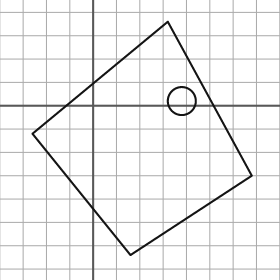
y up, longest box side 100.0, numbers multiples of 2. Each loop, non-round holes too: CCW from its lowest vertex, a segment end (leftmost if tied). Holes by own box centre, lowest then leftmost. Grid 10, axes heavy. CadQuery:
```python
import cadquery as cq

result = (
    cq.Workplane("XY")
    .moveTo(16.0, -64.0)
    .lineTo(68.0, -30.0)
    .lineTo(32.0, 36.0)
    .lineTo(-26.0, -12.0)
    .close()
    .moveTo(38.0, 2.0)
    .circle(6.0)
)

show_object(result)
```